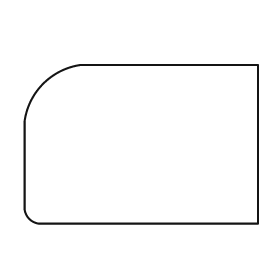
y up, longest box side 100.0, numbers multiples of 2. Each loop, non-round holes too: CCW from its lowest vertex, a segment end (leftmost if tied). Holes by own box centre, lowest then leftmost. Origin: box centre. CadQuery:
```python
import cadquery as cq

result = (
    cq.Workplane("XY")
    .moveTo(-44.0, -34.0)
    .lineTo(50.0, -34.0)
    .lineTo(50.0, 34.0)
    .lineTo(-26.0, 34.0)
    .threePointArc((-42.0, 26.0), (-50.0, 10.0))
    .lineTo(-50.0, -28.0)
    .threePointArc((-48.0, -32.0), (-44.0, -34.0))
    .close()
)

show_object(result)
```